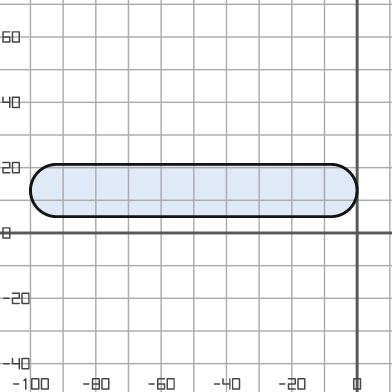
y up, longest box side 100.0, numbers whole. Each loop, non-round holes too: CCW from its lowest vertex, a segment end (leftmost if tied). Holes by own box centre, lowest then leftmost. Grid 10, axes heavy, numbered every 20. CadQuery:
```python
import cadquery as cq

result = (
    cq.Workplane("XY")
    .moveTo(-92.0, 5.0)
    .lineTo(-8.0, 5.0)
    .threePointArc((0.0, 13.0), (-8.0, 21.0))
    .lineTo(-92.0, 21.0)
    .threePointArc((-100.0, 13.0), (-92.0, 5.0))
    .close()
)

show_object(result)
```